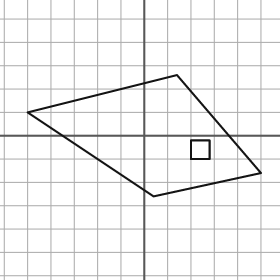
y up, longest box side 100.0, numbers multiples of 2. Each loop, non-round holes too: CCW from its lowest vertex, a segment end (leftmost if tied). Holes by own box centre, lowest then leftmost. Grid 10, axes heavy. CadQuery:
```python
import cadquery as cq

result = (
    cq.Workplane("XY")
    .moveTo(4.0, -26.0)
    .lineTo(50.0, -16.0)
    .lineTo(14.0, 26.0)
    .lineTo(-50.0, 10.0)
    .close()
    .moveTo(20.0, -10.0)
    .lineTo(28.0, -10.0)
    .lineTo(28.0, -2.0)
    .lineTo(20.0, -2.0)
    .close()
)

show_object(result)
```